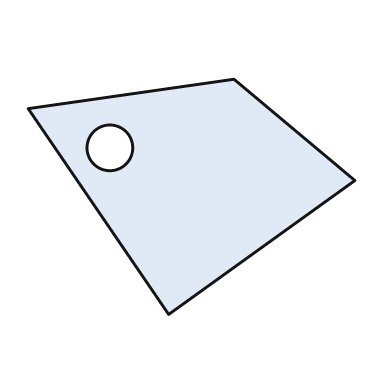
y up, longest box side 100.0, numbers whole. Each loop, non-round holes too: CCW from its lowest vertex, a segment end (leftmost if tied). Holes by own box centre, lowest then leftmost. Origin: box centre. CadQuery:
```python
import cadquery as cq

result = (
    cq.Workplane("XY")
    .moveTo(-7.0, -36.0)
    .lineTo(50.0, 5.0)
    .lineTo(13.0, 36.0)
    .lineTo(-50.0, 27.0)
    .close()
    .moveTo(-25.0, 15.0)
    .circle(7.0)
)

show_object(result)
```